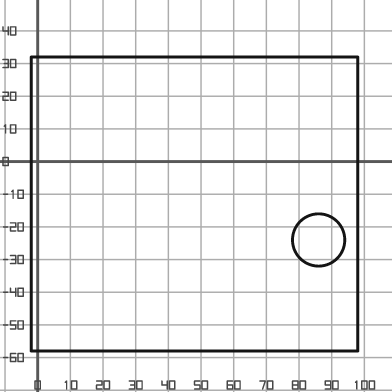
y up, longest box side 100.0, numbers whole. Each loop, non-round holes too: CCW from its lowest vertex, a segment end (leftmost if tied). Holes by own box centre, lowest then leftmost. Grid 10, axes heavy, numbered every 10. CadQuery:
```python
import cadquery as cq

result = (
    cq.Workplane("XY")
    .moveTo(-2.0, -58.0)
    .lineTo(98.0, -58.0)
    .lineTo(98.0, 32.0)
    .lineTo(-2.0, 32.0)
    .close()
    .moveTo(86.0, -24.0)
    .circle(8.0)
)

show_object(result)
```